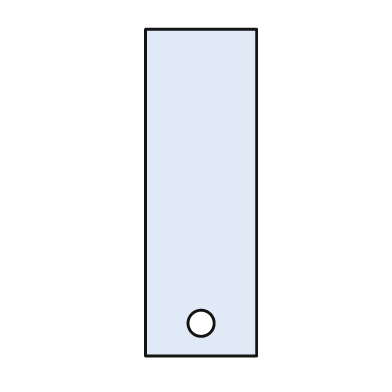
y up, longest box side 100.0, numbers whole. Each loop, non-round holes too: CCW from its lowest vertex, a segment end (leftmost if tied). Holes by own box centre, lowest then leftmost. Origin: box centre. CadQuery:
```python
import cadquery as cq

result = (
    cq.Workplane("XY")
    .moveTo(-17.0, -50.0)
    .lineTo(17.0, -50.0)
    .lineTo(17.0, 50.0)
    .lineTo(-17.0, 50.0)
    .close()
    .moveTo(0.0, -40.0)
    .circle(4.0)
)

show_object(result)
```